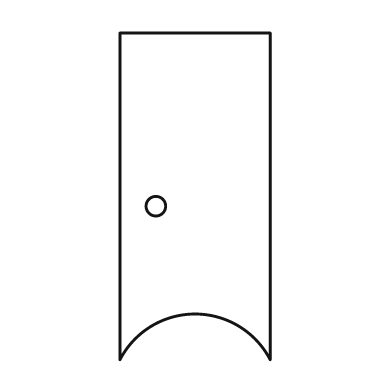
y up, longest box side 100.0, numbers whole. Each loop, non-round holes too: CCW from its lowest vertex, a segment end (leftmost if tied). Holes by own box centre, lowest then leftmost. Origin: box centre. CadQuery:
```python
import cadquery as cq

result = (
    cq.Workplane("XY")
    .moveTo(-23.0, -50.0)
    .threePointArc((0.0, -36.0), (23.0, -50.0))
    .lineTo(23.0, 50.0)
    .lineTo(-23.0, 50.0)
    .close()
    .moveTo(-12.0, -3.0)
    .circle(3.0)
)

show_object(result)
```